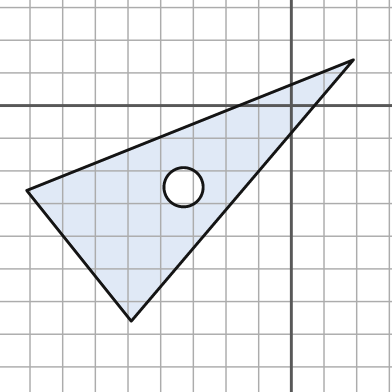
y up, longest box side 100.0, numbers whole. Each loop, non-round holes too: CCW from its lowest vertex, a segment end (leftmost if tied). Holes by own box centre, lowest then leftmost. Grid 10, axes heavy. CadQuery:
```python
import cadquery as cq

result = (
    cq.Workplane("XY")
    .moveTo(-49.0, -66.0)
    .lineTo(19.0, 14.0)
    .lineTo(-81.0, -26.0)
    .close()
    .moveTo(-33.0, -25.0)
    .circle(6.0)
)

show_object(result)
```